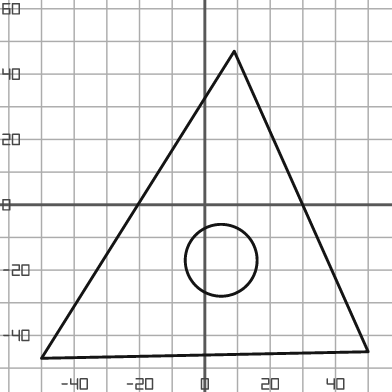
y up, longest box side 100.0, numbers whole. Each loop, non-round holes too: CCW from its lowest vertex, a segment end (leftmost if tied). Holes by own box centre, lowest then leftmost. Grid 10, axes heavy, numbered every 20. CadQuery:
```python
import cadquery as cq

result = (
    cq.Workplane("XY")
    .moveTo(-50.0, -47.0)
    .lineTo(50.0, -45.0)
    .lineTo(9.0, 47.0)
    .close()
    .moveTo(5.0, -17.0)
    .circle(11.0)
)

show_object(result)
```